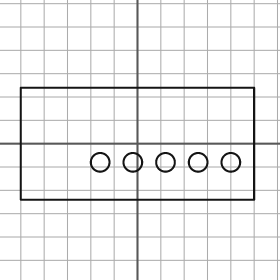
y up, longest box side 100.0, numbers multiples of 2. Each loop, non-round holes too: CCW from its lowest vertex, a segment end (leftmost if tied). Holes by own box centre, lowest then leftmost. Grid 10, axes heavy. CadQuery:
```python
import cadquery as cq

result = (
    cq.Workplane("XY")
    .moveTo(-50.0, -24.0)
    .lineTo(50.0, -24.0)
    .lineTo(50.0, 24.0)
    .lineTo(-50.0, 24.0)
    .close()
    .moveTo(-16.0, -8.0)
    .circle(4.0)
    .moveTo(-2.0, -8.0)
    .circle(4.0)
    .moveTo(12.0, -8.0)
    .circle(4.0)
    .moveTo(26.0, -8.0)
    .circle(4.0)
    .moveTo(40.0, -8.0)
    .circle(4.0)
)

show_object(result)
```